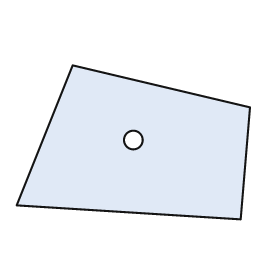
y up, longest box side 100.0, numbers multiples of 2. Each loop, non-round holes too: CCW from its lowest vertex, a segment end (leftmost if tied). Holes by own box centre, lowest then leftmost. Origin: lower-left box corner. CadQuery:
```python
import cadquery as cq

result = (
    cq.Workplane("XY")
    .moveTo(96.0, 0.0)
    .lineTo(100.0, 48.0)
    .lineTo(24.0, 66.0)
    .lineTo(0.0, 6.0)
    .close()
    .moveTo(50.0, 34.0)
    .circle(4.0)
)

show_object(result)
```